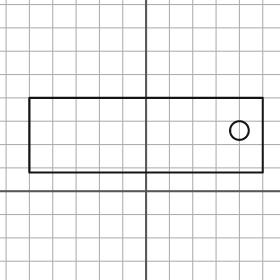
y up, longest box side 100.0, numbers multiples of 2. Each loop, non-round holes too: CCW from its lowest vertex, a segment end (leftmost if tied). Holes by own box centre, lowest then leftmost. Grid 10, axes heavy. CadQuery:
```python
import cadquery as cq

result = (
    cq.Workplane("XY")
    .moveTo(-50.0, 8.0)
    .lineTo(50.0, 8.0)
    .lineTo(50.0, 40.0)
    .lineTo(-50.0, 40.0)
    .close()
    .moveTo(40.0, 26.0)
    .circle(4.0)
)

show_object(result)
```